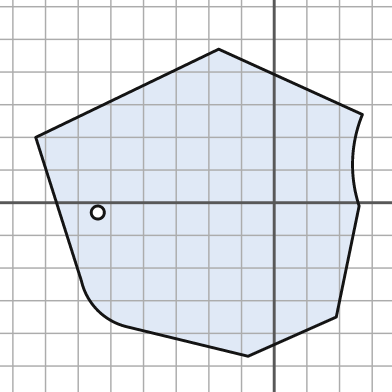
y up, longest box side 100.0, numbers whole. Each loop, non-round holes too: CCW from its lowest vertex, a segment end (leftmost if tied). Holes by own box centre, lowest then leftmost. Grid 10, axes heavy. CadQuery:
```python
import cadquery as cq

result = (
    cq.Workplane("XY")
    .moveTo(-8.0, -47.0)
    .lineTo(19.0, -35.0)
    .lineTo(26.0, -1.0)
    .threePointArc((24.0, 13.0), (27.0, 27.0))
    .lineTo(-17.0, 47.0)
    .lineTo(-73.0, 20.0)
    .lineTo(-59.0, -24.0)
    .threePointArc((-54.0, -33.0), (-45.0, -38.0))
    .close()
    .moveTo(-54.0, -3.0)
    .circle(2.0)
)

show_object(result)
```